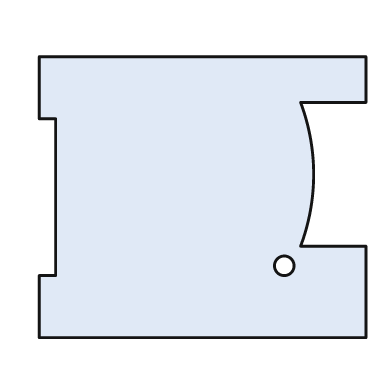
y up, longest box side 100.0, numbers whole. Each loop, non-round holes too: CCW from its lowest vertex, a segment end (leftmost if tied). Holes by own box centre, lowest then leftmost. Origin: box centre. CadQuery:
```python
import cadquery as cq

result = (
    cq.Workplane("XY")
    .moveTo(-50.0, -43.0)
    .lineTo(50.0, -43.0)
    .lineTo(50.0, -15.0)
    .lineTo(30.0, -15.0)
    .threePointArc((34.0, 7.0), (30.0, 29.0))
    .lineTo(50.0, 29.0)
    .lineTo(50.0, 43.0)
    .lineTo(-50.0, 43.0)
    .lineTo(-50.0, 24.0)
    .lineTo(-45.0, 24.0)
    .lineTo(-45.0, -24.0)
    .lineTo(-50.0, -24.0)
    .close()
    .moveTo(25.0, -21.0)
    .circle(3.0)
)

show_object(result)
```